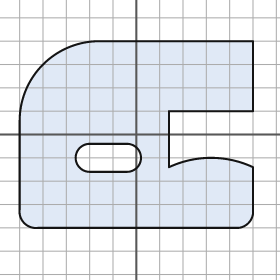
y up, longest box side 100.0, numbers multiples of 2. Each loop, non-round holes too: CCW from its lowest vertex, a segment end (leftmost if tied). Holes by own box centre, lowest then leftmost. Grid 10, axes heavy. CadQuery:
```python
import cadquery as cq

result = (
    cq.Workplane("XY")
    .moveTo(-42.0, -40.0)
    .lineTo(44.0, -40.0)
    .threePointArc((48.0, -38.0), (50.0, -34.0))
    .lineTo(50.0, -14.0)
    .threePointArc((32.0, -10.0), (14.0, -14.0))
    .lineTo(14.0, 10.0)
    .lineTo(50.0, 10.0)
    .lineTo(50.0, 40.0)
    .lineTo(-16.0, 40.0)
    .threePointArc((-40.0, 30.0), (-50.0, 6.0))
    .lineTo(-50.0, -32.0)
    .threePointArc((-48.0, -38.0), (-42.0, -40.0))
    .close()
    .moveTo(-20.0, -16.0)
    .lineTo(-4.0, -16.0)
    .threePointArc((2.0, -10.0), (-4.0, -4.0))
    .lineTo(-20.0, -4.0)
    .threePointArc((-26.0, -10.0), (-20.0, -16.0))
    .close()
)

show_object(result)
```